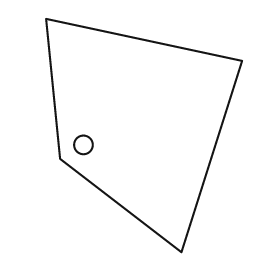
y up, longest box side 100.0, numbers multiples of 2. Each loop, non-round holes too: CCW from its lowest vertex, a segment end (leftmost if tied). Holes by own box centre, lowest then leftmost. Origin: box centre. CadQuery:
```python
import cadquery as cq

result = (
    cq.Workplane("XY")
    .moveTo(16.0, -50.0)
    .lineTo(42.0, 32.0)
    .lineTo(-42.0, 50.0)
    .lineTo(-36.0, -10.0)
    .close()
    .moveTo(-26.0, -4.0)
    .circle(4.0)
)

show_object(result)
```